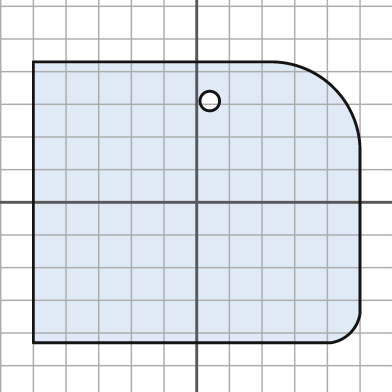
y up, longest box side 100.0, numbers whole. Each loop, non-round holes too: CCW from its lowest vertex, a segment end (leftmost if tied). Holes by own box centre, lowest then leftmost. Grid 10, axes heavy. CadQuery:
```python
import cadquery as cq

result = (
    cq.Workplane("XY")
    .moveTo(-50.0, -43.0)
    .lineTo(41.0, -43.0)
    .threePointArc((47.0, -40.0), (50.0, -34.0))
    .lineTo(50.0, 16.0)
    .threePointArc((42.0, 35.0), (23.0, 43.0))
    .lineTo(-50.0, 43.0)
    .close()
    .moveTo(4.0, 31.0)
    .circle(3.0)
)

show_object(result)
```